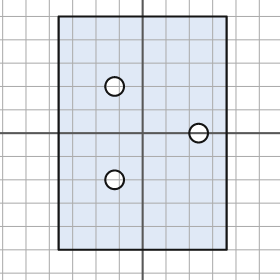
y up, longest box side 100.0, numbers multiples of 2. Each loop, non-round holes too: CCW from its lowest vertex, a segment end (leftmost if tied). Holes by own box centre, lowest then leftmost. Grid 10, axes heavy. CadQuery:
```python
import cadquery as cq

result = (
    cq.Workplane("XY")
    .moveTo(-36.0, -50.0)
    .lineTo(36.0, -50.0)
    .lineTo(36.0, 50.0)
    .lineTo(-36.0, 50.0)
    .close()
    .moveTo(-12.0, -20.0)
    .circle(4.0)
    .moveTo(24.0, 0.0)
    .circle(4.0)
    .moveTo(-12.0, 20.0)
    .circle(4.0)
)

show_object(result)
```